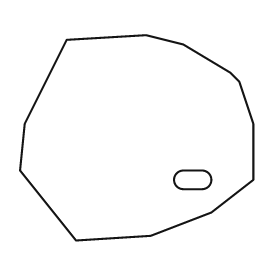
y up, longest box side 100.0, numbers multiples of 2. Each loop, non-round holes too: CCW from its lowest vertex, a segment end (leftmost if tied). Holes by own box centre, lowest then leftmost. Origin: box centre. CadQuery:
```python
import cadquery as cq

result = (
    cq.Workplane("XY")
    .moveTo(-26.0, -44.0)
    .lineTo(6.0, -42.0)
    .lineTo(32.0, -32.0)
    .lineTo(50.0, -18.0)
    .lineTo(50.0, 6.0)
    .lineTo(44.0, 24.0)
    .lineTo(40.0, 28.0)
    .lineTo(20.0, 40.0)
    .lineTo(4.0, 44.0)
    .lineTo(-30.0, 42.0)
    .lineTo(-48.0, 6.0)
    .lineTo(-50.0, -14.0)
    .close()
    .moveTo(20.0, -22.0)
    .lineTo(28.0, -22.0)
    .threePointArc((32.0, -18.0), (28.0, -14.0))
    .lineTo(20.0, -14.0)
    .threePointArc((16.0, -18.0), (20.0, -22.0))
    .close()
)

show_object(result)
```